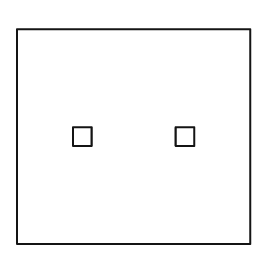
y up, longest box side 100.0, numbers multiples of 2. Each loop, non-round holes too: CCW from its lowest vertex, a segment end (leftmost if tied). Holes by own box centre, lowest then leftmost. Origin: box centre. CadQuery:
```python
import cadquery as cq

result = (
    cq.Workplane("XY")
    .moveTo(-50.0, -46.0)
    .lineTo(50.0, -46.0)
    .lineTo(50.0, 46.0)
    .lineTo(-50.0, 46.0)
    .close()
    .moveTo(-26.0, -4.0)
    .lineTo(-18.0, -4.0)
    .lineTo(-18.0, 4.0)
    .lineTo(-26.0, 4.0)
    .close()
    .moveTo(18.0, -4.0)
    .lineTo(26.0, -4.0)
    .lineTo(26.0, 4.0)
    .lineTo(18.0, 4.0)
    .close()
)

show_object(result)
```